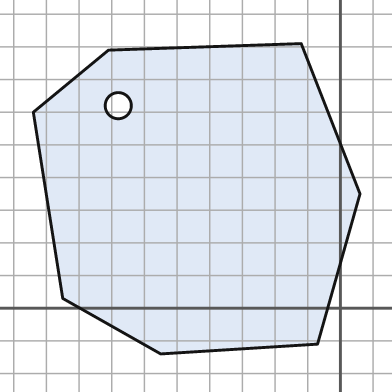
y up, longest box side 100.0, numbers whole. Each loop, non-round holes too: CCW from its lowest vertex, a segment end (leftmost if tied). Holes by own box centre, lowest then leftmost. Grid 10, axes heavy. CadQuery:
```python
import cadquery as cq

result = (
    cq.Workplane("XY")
    .moveTo(-55.0, -14.0)
    .lineTo(-7.0, -11.0)
    .lineTo(6.0, 35.0)
    .lineTo(-12.0, 81.0)
    .lineTo(-71.0, 79.0)
    .lineTo(-94.0, 60.0)
    .lineTo(-85.0, 3.0)
    .close()
    .moveTo(-68.0, 62.0)
    .circle(4.0)
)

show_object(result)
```